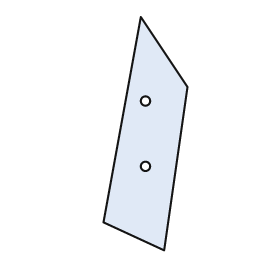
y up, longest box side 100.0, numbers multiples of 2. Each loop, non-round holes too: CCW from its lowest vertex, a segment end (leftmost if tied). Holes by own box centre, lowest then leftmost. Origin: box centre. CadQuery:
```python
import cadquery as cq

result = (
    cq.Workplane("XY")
    .moveTo(8.0, -50.0)
    .lineTo(18.0, 20.0)
    .lineTo(-2.0, 50.0)
    .lineTo(-18.0, -38.0)
    .close()
    .moveTo(0.0, -14.0)
    .circle(2.0)
    .moveTo(0.0, 14.0)
    .circle(2.0)
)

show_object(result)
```